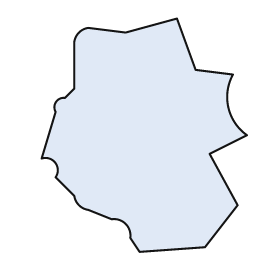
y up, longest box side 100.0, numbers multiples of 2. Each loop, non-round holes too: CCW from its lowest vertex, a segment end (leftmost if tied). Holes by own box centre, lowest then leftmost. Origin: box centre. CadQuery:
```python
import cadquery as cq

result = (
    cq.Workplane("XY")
    .moveTo(-2.0, -50.0)
    .lineTo(26.0, -48.0)
    .lineTo(40.0, -30.0)
    .lineTo(28.0, -8.0)
    .lineTo(44.0, 0.0)
    .threePointArc((36.0, 12.0), (38.0, 26.0))
    .lineTo(22.0, 28.0)
    .lineTo(14.0, 50.0)
    .lineTo(-8.0, 44.0)
    .lineTo(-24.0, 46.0)
    .threePointArc((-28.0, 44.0), (-30.0, 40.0))
    .lineTo(-30.0, 20.0)
    .lineTo(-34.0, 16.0)
    .threePointArc((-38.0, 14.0), (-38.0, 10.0))
    .lineTo(-44.0, -10.0)
    .threePointArc((-38.0, -12.0), (-38.0, -18.0))
    .lineTo(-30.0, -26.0)
    .threePointArc((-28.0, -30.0), (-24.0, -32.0))
    .lineTo(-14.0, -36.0)
    .threePointArc((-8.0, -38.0), (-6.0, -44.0))
    .close()
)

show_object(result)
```